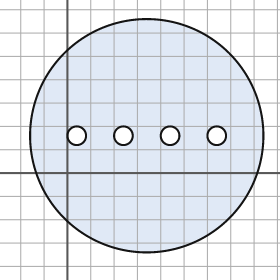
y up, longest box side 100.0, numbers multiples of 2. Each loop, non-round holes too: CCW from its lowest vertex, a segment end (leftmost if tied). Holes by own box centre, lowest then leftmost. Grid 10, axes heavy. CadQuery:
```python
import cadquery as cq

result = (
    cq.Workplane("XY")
    .moveTo(34.0, 16.0)
    .circle(50.0)
    .moveTo(4.0, 16.0)
    .circle(4.0)
    .moveTo(24.0, 16.0)
    .circle(4.0)
    .moveTo(44.0, 16.0)
    .circle(4.0)
    .moveTo(64.0, 16.0)
    .circle(4.0)
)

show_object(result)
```